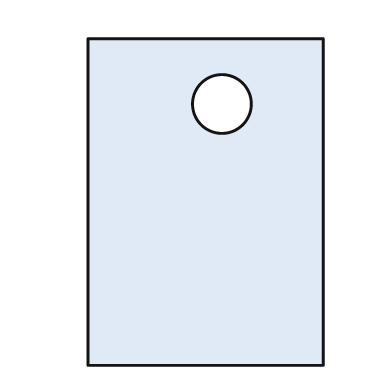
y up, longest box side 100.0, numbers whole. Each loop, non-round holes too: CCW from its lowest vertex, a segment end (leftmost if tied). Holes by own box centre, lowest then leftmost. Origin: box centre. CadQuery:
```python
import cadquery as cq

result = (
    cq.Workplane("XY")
    .moveTo(-36.0, -50.0)
    .lineTo(36.0, -50.0)
    .lineTo(36.0, 50.0)
    .lineTo(-36.0, 50.0)
    .close()
    .moveTo(5.0, 30.0)
    .circle(9.0)
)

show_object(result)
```